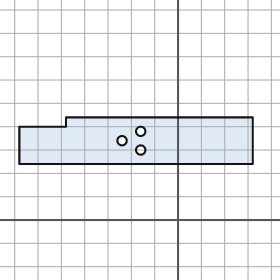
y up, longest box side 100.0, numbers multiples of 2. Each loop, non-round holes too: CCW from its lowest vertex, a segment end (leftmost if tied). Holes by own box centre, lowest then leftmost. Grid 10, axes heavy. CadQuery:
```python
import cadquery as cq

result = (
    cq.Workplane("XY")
    .moveTo(-68.0, 24.0)
    .lineTo(32.0, 24.0)
    .lineTo(32.0, 44.0)
    .lineTo(-48.0, 44.0)
    .lineTo(-48.0, 40.0)
    .lineTo(-68.0, 40.0)
    .close()
    .moveTo(-16.0, 30.0)
    .circle(2.0)
    .moveTo(-24.0, 34.0)
    .circle(2.0)
    .moveTo(-16.0, 38.0)
    .circle(2.0)
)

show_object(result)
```